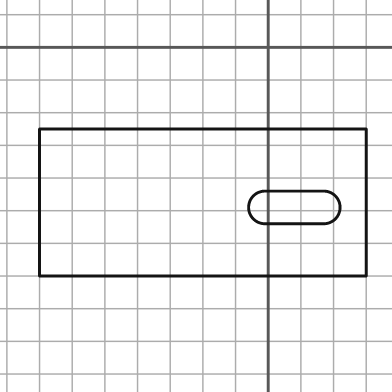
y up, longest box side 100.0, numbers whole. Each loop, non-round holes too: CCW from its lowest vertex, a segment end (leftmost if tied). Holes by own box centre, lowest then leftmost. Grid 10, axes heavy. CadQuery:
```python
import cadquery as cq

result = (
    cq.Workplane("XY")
    .moveTo(-70.0, -70.0)
    .lineTo(30.0, -70.0)
    .lineTo(30.0, -25.0)
    .lineTo(-70.0, -25.0)
    .close()
    .moveTo(-1.0, -54.0)
    .lineTo(17.0, -54.0)
    .threePointArc((22.0, -49.0), (17.0, -44.0))
    .lineTo(-1.0, -44.0)
    .threePointArc((-6.0, -49.0), (-1.0, -54.0))
    .close()
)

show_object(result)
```